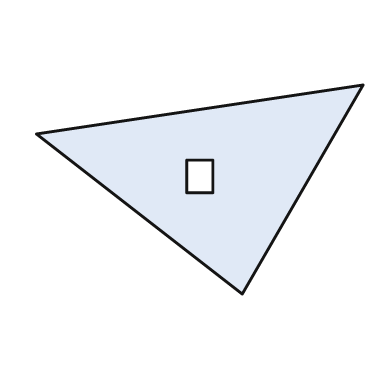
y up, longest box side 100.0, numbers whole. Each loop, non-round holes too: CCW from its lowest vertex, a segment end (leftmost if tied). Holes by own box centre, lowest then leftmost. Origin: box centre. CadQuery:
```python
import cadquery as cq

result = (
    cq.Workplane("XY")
    .moveTo(13.0, -32.0)
    .lineTo(50.0, 32.0)
    .lineTo(-50.0, 17.0)
    .close()
    .moveTo(-4.0, -1.0)
    .lineTo(4.0, -1.0)
    .lineTo(4.0, 9.0)
    .lineTo(-4.0, 9.0)
    .close()
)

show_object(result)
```